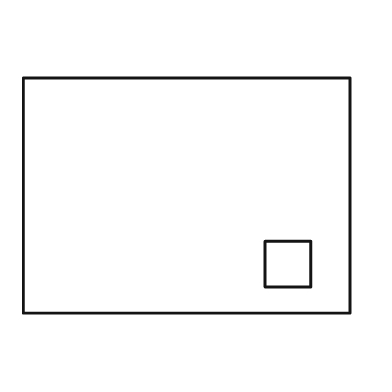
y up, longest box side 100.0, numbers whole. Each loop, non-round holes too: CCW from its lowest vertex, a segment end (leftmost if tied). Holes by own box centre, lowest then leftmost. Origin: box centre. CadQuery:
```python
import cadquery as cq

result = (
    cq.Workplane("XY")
    .moveTo(-50.0, -36.0)
    .lineTo(50.0, -36.0)
    .lineTo(50.0, 36.0)
    .lineTo(-50.0, 36.0)
    .close()
    .moveTo(24.0, -28.0)
    .lineTo(38.0, -28.0)
    .lineTo(38.0, -14.0)
    .lineTo(24.0, -14.0)
    .close()
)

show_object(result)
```